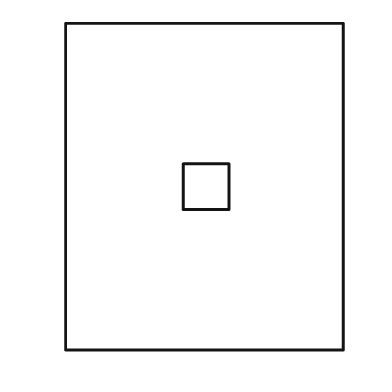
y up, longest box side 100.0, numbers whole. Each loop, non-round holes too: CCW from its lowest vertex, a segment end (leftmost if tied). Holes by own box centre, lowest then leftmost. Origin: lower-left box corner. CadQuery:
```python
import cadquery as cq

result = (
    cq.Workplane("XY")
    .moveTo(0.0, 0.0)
    .lineTo(85.0, 0.0)
    .lineTo(85.0, 100.0)
    .lineTo(0.0, 100.0)
    .close()
    .moveTo(36.0, 43.0)
    .lineTo(50.0, 43.0)
    .lineTo(50.0, 57.0)
    .lineTo(36.0, 57.0)
    .close()
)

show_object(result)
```